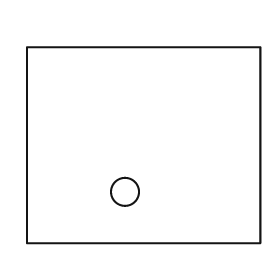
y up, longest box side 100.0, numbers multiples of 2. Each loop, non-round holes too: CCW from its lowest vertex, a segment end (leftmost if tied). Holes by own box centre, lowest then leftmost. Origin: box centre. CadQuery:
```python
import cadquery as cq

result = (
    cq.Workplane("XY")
    .moveTo(-50.0, -42.0)
    .lineTo(50.0, -42.0)
    .lineTo(50.0, 42.0)
    .lineTo(-50.0, 42.0)
    .close()
    .moveTo(-8.0, -20.0)
    .circle(6.0)
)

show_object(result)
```